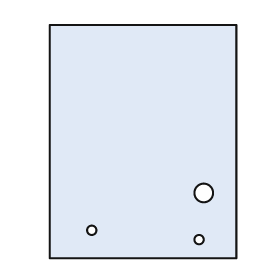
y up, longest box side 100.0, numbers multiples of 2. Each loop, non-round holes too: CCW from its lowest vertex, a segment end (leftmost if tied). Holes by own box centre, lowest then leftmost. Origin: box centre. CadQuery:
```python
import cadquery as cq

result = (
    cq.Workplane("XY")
    .moveTo(-40.0, -50.0)
    .lineTo(40.0, -50.0)
    .lineTo(40.0, 50.0)
    .lineTo(-40.0, 50.0)
    .close()
    .moveTo(24.0, -42.0)
    .circle(2.0)
    .moveTo(-22.0, -38.0)
    .circle(2.0)
    .moveTo(26.0, -22.0)
    .circle(4.0)
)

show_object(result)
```